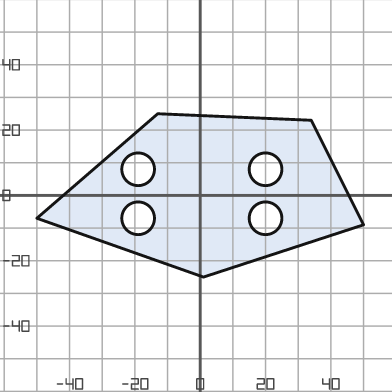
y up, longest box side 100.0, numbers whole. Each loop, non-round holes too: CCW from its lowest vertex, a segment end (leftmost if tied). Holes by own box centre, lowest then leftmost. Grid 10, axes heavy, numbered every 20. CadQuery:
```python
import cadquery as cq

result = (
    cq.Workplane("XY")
    .moveTo(1.0, -25.0)
    .lineTo(50.0, -9.0)
    .lineTo(34.0, 23.0)
    .lineTo(-13.0, 25.0)
    .lineTo(-50.0, -7.0)
    .close()
    .moveTo(-19.0, -7.0)
    .circle(5.0)
    .moveTo(20.0, -7.0)
    .circle(5.0)
    .moveTo(-19.0, 8.0)
    .circle(5.0)
    .moveTo(20.0, 8.0)
    .circle(5.0)
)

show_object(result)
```